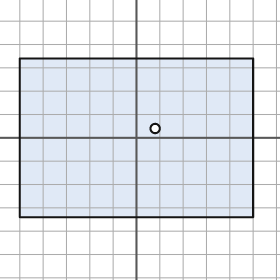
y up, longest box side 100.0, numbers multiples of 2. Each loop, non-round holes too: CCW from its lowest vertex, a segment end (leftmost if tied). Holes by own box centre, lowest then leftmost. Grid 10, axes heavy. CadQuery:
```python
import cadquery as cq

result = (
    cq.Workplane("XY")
    .moveTo(-50.0, -34.0)
    .lineTo(50.0, -34.0)
    .lineTo(50.0, 34.0)
    .lineTo(-50.0, 34.0)
    .close()
    .moveTo(8.0, 4.0)
    .circle(2.0)
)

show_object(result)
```